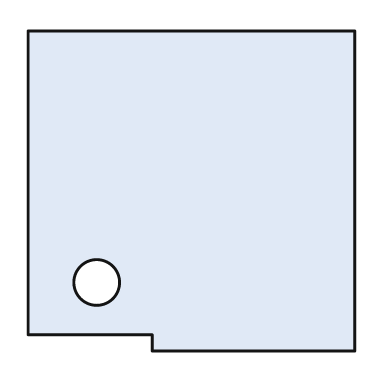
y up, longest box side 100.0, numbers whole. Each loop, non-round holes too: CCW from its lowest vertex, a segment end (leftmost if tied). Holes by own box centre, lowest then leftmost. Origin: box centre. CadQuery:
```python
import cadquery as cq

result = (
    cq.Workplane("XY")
    .moveTo(-12.0, -49.0)
    .lineTo(50.0, -49.0)
    .lineTo(50.0, 49.0)
    .lineTo(-50.0, 49.0)
    .lineTo(-50.0, -44.0)
    .lineTo(-12.0, -44.0)
    .close()
    .moveTo(-29.0, -28.0)
    .circle(7.0)
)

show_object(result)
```